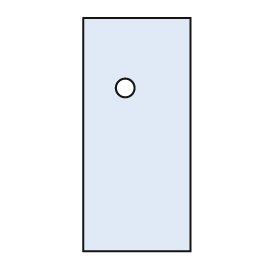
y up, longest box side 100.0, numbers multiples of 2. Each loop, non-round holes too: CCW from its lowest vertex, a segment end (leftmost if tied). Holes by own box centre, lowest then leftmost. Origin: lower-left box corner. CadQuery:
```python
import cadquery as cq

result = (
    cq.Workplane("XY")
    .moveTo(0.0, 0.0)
    .lineTo(46.0, 0.0)
    .lineTo(46.0, 100.0)
    .lineTo(0.0, 100.0)
    .close()
    .moveTo(18.0, 70.0)
    .circle(4.0)
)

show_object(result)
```